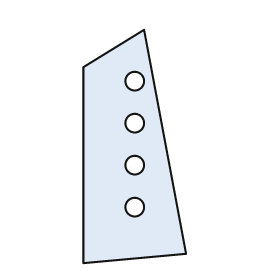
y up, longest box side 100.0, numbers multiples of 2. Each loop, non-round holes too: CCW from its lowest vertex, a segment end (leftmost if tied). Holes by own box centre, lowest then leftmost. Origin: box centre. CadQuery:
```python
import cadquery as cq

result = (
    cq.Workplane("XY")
    .moveTo(-22.0, -50.0)
    .lineTo(22.0, -46.0)
    .lineTo(4.0, 50.0)
    .lineTo(-22.0, 34.0)
    .close()
    .moveTo(0.0, -26.0)
    .circle(4.0)
    .moveTo(0.0, -8.0)
    .circle(4.0)
    .moveTo(0.0, 10.0)
    .circle(4.0)
    .moveTo(0.0, 28.0)
    .circle(4.0)
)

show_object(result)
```